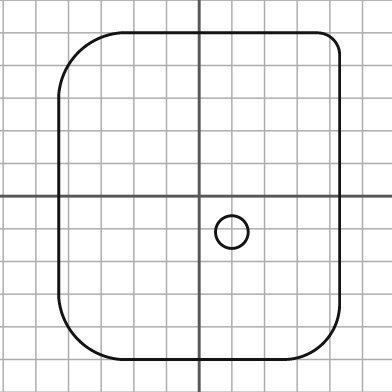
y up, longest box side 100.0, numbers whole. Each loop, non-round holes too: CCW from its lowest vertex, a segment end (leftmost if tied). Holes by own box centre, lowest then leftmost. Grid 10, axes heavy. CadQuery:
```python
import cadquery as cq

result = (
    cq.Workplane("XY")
    .moveTo(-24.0, -50.0)
    .lineTo(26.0, -50.0)
    .threePointArc((38.0, -45.0), (43.0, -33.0))
    .lineTo(43.0, 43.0)
    .threePointArc((41.0, 48.0), (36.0, 50.0))
    .lineTo(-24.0, 50.0)
    .threePointArc((-37.0, 44.0), (-43.0, 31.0))
    .lineTo(-43.0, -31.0)
    .threePointArc((-37.0, -44.0), (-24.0, -50.0))
    .close()
    .moveTo(10.0, -11.0)
    .circle(5.0)
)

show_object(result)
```